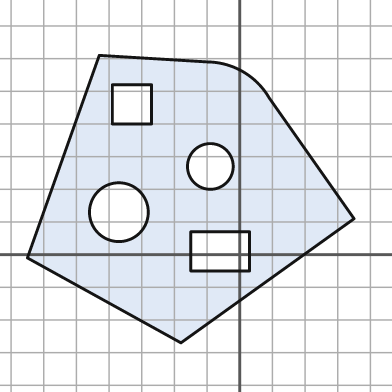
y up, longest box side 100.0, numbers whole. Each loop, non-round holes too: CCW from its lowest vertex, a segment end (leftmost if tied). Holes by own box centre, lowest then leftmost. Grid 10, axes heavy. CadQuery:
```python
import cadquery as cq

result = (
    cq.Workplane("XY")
    .moveTo(-18.0, -27.0)
    .lineTo(35.0, 11.0)
    .lineTo(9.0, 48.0)
    .threePointArc((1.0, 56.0), (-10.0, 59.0))
    .lineTo(-43.0, 61.0)
    .lineTo(-65.0, -1.0)
    .close()
    .moveTo(-15.0, -5.0)
    .lineTo(3.0, -5.0)
    .lineTo(3.0, 7.0)
    .lineTo(-15.0, 7.0)
    .close()
    .moveTo(-37.0, 13.0)
    .circle(9.0)
    .moveTo(-9.0, 27.0)
    .circle(7.0)
    .moveTo(-39.0, 40.0)
    .lineTo(-27.0, 40.0)
    .lineTo(-27.0, 52.0)
    .lineTo(-39.0, 52.0)
    .close()
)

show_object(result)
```